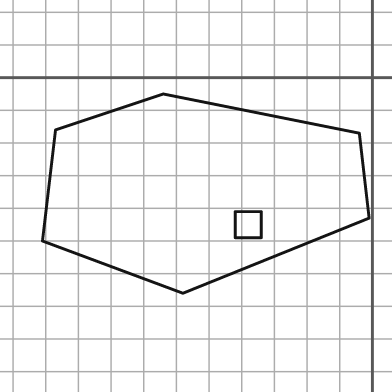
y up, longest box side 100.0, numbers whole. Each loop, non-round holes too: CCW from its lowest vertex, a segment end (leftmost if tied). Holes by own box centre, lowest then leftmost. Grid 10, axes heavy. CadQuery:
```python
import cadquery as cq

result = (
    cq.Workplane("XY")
    .moveTo(-58.0, -66.0)
    .lineTo(-1.0, -43.0)
    .lineTo(-4.0, -17.0)
    .lineTo(-64.0, -5.0)
    .lineTo(-97.0, -16.0)
    .lineTo(-101.0, -50.0)
    .close()
    .moveTo(-42.0, -49.0)
    .lineTo(-34.0, -49.0)
    .lineTo(-34.0, -41.0)
    .lineTo(-42.0, -41.0)
    .close()
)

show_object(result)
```